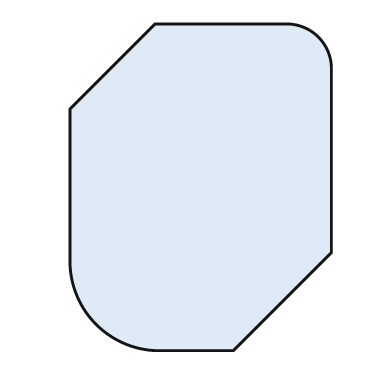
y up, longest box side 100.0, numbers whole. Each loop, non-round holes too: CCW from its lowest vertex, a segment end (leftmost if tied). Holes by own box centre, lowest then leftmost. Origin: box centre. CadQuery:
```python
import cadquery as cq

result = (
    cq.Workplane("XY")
    .moveTo(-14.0, -50.0)
    .lineTo(10.0, -50.0)
    .lineTo(40.0, -20.0)
    .lineTo(40.0, 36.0)
    .threePointArc((36.0, 46.0), (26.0, 50.0))
    .lineTo(-14.0, 50.0)
    .lineTo(-40.0, 24.0)
    .lineTo(-40.0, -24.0)
    .threePointArc((-32.0, -42.0), (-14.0, -50.0))
    .close()
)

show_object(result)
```